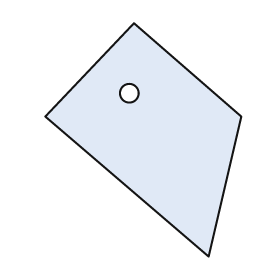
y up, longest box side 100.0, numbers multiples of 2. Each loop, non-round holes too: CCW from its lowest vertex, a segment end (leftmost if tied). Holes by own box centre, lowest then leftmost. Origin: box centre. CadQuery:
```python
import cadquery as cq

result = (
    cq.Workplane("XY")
    .moveTo(28.0, -50.0)
    .lineTo(42.0, 10.0)
    .lineTo(-4.0, 50.0)
    .lineTo(-42.0, 10.0)
    .close()
    .moveTo(-6.0, 20.0)
    .circle(4.0)
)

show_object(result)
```